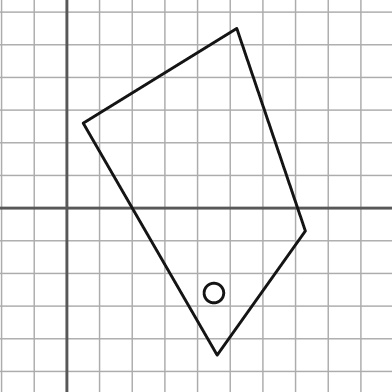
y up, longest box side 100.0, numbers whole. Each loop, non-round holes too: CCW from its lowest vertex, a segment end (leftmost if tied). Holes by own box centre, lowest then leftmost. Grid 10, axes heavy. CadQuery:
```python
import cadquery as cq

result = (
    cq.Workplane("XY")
    .moveTo(46.0, -45.0)
    .lineTo(73.0, -7.0)
    .lineTo(52.0, 55.0)
    .lineTo(5.0, 26.0)
    .close()
    .moveTo(45.0, -26.0)
    .circle(3.0)
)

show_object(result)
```